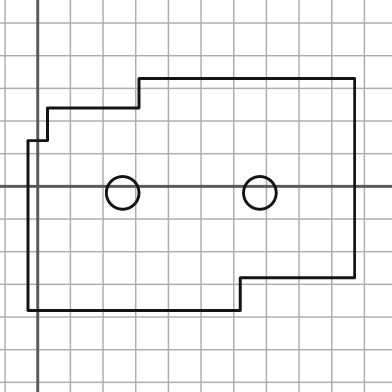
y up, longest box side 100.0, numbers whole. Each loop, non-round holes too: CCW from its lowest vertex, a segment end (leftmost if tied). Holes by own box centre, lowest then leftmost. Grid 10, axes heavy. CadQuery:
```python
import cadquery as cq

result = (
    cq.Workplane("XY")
    .moveTo(-3.0, -38.0)
    .lineTo(62.0, -38.0)
    .lineTo(62.0, -28.0)
    .lineTo(97.0, -28.0)
    .lineTo(97.0, 33.0)
    .lineTo(31.0, 33.0)
    .lineTo(31.0, 24.0)
    .lineTo(3.0, 24.0)
    .lineTo(3.0, 14.0)
    .lineTo(-3.0, 14.0)
    .close()
    .moveTo(26.0, -2.0)
    .circle(5.0)
    .moveTo(68.0, -2.0)
    .circle(5.0)
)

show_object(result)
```